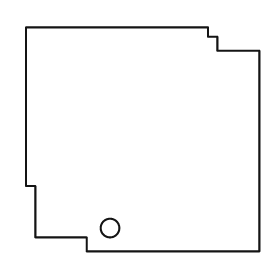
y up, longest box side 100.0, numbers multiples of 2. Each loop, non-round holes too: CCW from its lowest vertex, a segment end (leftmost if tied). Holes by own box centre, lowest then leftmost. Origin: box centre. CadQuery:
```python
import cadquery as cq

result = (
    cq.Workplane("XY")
    .moveTo(-24.0, -48.0)
    .lineTo(50.0, -48.0)
    .lineTo(50.0, 38.0)
    .lineTo(32.0, 38.0)
    .lineTo(32.0, 44.0)
    .lineTo(28.0, 44.0)
    .lineTo(28.0, 48.0)
    .lineTo(-50.0, 48.0)
    .lineTo(-50.0, -20.0)
    .lineTo(-46.0, -20.0)
    .lineTo(-46.0, -42.0)
    .lineTo(-24.0, -42.0)
    .close()
    .moveTo(-14.0, -38.0)
    .circle(4.0)
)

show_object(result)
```